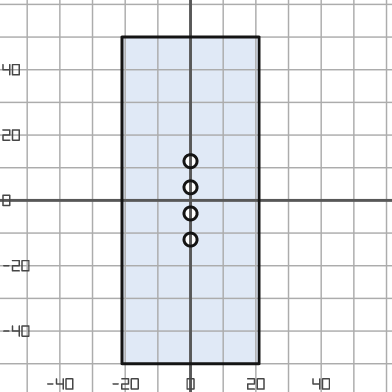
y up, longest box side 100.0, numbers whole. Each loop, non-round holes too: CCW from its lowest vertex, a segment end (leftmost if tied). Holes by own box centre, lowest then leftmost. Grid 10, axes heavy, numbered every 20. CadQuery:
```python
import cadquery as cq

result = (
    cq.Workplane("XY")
    .moveTo(-21.0, -50.0)
    .lineTo(21.0, -50.0)
    .lineTo(21.0, 50.0)
    .lineTo(-21.0, 50.0)
    .close()
    .moveTo(0.0, -12.0)
    .circle(2.0)
    .moveTo(0.0, -4.0)
    .circle(2.0)
    .moveTo(0.0, 4.0)
    .circle(2.0)
    .moveTo(0.0, 12.0)
    .circle(2.0)
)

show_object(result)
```